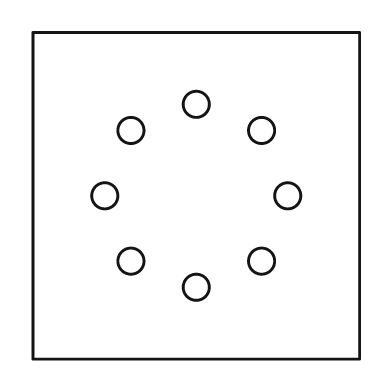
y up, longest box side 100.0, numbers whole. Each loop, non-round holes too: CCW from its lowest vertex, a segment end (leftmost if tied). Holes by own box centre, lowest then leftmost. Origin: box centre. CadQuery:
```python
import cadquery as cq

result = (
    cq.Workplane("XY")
    .moveTo(-50.0, -50.0)
    .lineTo(50.0, -50.0)
    .lineTo(50.0, 50.0)
    .lineTo(-50.0, 50.0)
    .close()
    .moveTo(0.0, -28.0)
    .circle(4.0)
    .moveTo(-20.0, -20.0)
    .circle(4.0)
    .moveTo(20.0, -20.0)
    .circle(4.0)
    .moveTo(-28.0, 0.0)
    .circle(4.0)
    .moveTo(28.0, 0.0)
    .circle(4.0)
    .moveTo(-20.0, 20.0)
    .circle(4.0)
    .moveTo(20.0, 20.0)
    .circle(4.0)
    .moveTo(0.0, 28.0)
    .circle(4.0)
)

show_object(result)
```